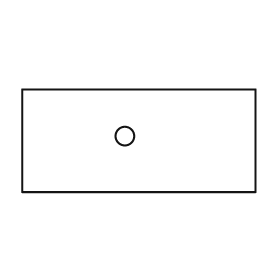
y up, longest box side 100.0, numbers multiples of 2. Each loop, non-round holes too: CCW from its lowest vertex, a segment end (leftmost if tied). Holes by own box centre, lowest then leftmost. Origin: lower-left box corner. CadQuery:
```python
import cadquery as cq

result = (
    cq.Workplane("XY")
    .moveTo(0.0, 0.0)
    .lineTo(100.0, 0.0)
    .lineTo(100.0, 44.0)
    .lineTo(0.0, 44.0)
    .close()
    .moveTo(44.0, 24.0)
    .circle(4.0)
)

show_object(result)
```